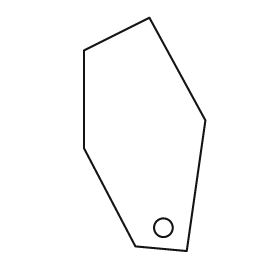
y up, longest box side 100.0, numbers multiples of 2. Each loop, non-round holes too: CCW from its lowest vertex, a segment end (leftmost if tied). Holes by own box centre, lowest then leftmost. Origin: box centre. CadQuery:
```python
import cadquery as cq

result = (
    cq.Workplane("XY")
    .moveTo(18.0, -50.0)
    .lineTo(26.0, 6.0)
    .lineTo(2.0, 50.0)
    .lineTo(-26.0, 36.0)
    .lineTo(-26.0, -6.0)
    .lineTo(-4.0, -48.0)
    .close()
    .moveTo(8.0, -40.0)
    .circle(4.0)
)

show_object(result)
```